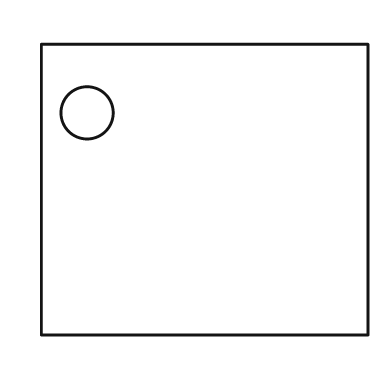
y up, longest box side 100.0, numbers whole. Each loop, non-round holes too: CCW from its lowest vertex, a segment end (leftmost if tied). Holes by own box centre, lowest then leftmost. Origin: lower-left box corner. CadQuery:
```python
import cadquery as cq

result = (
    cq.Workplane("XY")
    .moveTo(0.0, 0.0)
    .lineTo(100.0, 0.0)
    .lineTo(100.0, 89.0)
    .lineTo(0.0, 89.0)
    .close()
    .moveTo(14.0, 68.0)
    .circle(8.0)
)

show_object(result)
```